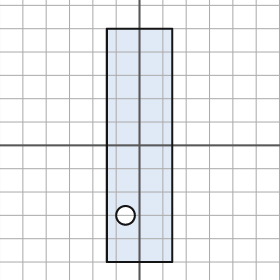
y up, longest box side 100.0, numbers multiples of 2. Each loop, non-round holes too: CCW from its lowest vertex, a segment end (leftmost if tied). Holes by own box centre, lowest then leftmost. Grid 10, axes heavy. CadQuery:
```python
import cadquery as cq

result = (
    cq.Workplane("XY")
    .moveTo(-14.0, -50.0)
    .lineTo(14.0, -50.0)
    .lineTo(14.0, 50.0)
    .lineTo(-14.0, 50.0)
    .close()
    .moveTo(-6.0, -30.0)
    .circle(4.0)
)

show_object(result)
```